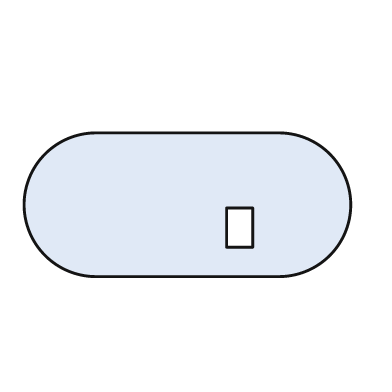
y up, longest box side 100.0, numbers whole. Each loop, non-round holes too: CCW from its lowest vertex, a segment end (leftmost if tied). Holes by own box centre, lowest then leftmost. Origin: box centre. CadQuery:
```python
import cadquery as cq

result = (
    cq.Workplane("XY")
    .moveTo(-28.0, -22.0)
    .lineTo(28.0, -22.0)
    .threePointArc((50.0, 0.0), (28.0, 22.0))
    .lineTo(-28.0, 22.0)
    .threePointArc((-50.0, 0.0), (-28.0, -22.0))
    .close()
    .moveTo(12.0, -13.0)
    .lineTo(20.0, -13.0)
    .lineTo(20.0, -1.0)
    .lineTo(12.0, -1.0)
    .close()
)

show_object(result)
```